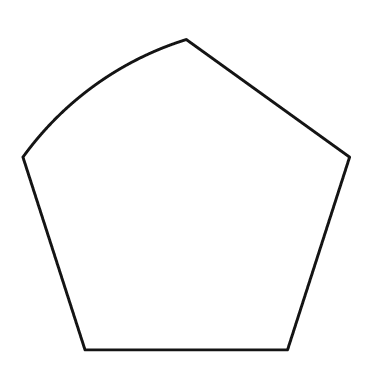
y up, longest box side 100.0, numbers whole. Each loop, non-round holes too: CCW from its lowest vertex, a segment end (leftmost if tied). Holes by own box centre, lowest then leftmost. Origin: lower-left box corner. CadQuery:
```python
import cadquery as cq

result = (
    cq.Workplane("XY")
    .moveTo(19.0, 0.0)
    .lineTo(81.0, 0.0)
    .lineTo(100.0, 59.0)
    .lineTo(50.0, 95.0)
    .threePointArc((22.0, 81.0), (0.0, 59.0))
    .close()
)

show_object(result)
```